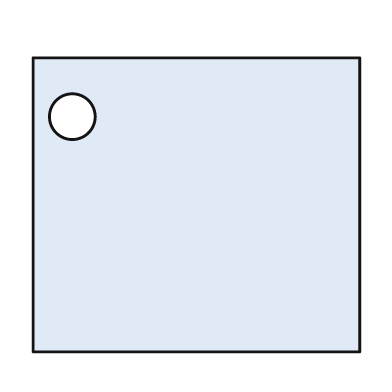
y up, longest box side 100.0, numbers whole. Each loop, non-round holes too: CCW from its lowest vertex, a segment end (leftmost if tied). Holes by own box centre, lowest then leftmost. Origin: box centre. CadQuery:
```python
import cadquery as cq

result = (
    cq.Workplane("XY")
    .moveTo(-50.0, -45.0)
    .lineTo(50.0, -45.0)
    .lineTo(50.0, 45.0)
    .lineTo(-50.0, 45.0)
    .close()
    .moveTo(-38.0, 27.0)
    .circle(7.0)
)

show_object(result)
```